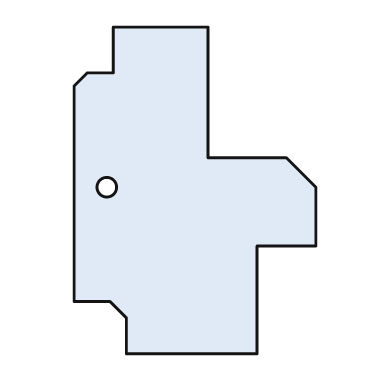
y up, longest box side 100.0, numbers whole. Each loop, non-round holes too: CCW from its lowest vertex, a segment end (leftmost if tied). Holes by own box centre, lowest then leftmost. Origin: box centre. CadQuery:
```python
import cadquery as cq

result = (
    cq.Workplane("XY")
    .moveTo(-21.0, -50.0)
    .lineTo(19.0, -50.0)
    .lineTo(19.0, -17.0)
    .lineTo(37.0, -17.0)
    .lineTo(37.0, 1.0)
    .lineTo(28.0, 10.0)
    .lineTo(4.0, 10.0)
    .lineTo(4.0, 50.0)
    .lineTo(-25.0, 50.0)
    .lineTo(-25.0, 36.0)
    .lineTo(-33.0, 36.0)
    .lineTo(-37.0, 32.0)
    .lineTo(-37.0, -34.0)
    .lineTo(-26.0, -34.0)
    .lineTo(-21.0, -39.0)
    .close()
    .moveTo(-27.0, 1.0)
    .circle(3.0)
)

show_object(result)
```